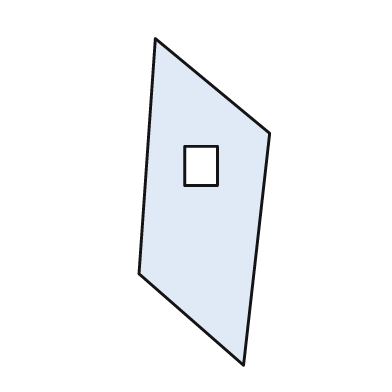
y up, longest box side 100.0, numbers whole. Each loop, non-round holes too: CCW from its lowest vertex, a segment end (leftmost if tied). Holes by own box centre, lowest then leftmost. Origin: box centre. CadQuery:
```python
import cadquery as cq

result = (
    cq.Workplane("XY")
    .moveTo(12.0, -50.0)
    .lineTo(20.0, 21.0)
    .lineTo(-15.0, 50.0)
    .lineTo(-20.0, -22.0)
    .close()
    .moveTo(-6.0, 5.0)
    .lineTo(4.0, 5.0)
    .lineTo(4.0, 17.0)
    .lineTo(-6.0, 17.0)
    .close()
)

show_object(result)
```